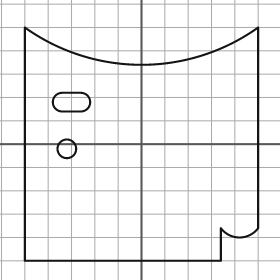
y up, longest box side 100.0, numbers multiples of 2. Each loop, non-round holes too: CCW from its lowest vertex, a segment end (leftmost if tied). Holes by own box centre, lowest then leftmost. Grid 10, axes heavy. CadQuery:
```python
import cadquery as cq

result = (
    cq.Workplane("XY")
    .moveTo(-50.0, -50.0)
    .lineTo(34.0, -50.0)
    .lineTo(34.0, -36.0)
    .threePointArc((42.0, -40.0), (50.0, -36.0))
    .lineTo(50.0, 50.0)
    .threePointArc((0.0, 34.0), (-50.0, 50.0))
    .close()
    .moveTo(-32.0, -2.0)
    .circle(4.0)
    .moveTo(-34.0, 14.0)
    .lineTo(-26.0, 14.0)
    .threePointArc((-22.0, 18.0), (-26.0, 22.0))
    .lineTo(-34.0, 22.0)
    .threePointArc((-38.0, 18.0), (-34.0, 14.0))
    .close()
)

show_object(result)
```